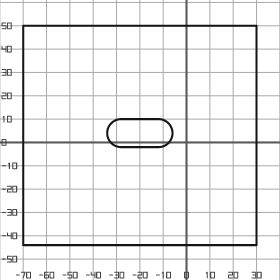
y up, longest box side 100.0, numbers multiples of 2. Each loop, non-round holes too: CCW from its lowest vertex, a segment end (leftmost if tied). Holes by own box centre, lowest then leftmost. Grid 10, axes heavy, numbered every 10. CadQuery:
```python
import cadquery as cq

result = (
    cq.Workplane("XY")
    .moveTo(-70.0, -44.0)
    .lineTo(30.0, -44.0)
    .lineTo(30.0, 50.0)
    .lineTo(-70.0, 50.0)
    .close()
    .moveTo(-28.0, -2.0)
    .lineTo(-12.0, -2.0)
    .threePointArc((-6.0, 4.0), (-12.0, 10.0))
    .lineTo(-28.0, 10.0)
    .threePointArc((-34.0, 4.0), (-28.0, -2.0))
    .close()
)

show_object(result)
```